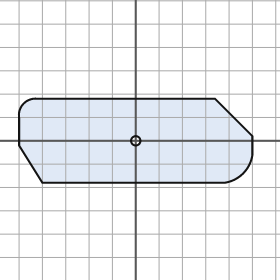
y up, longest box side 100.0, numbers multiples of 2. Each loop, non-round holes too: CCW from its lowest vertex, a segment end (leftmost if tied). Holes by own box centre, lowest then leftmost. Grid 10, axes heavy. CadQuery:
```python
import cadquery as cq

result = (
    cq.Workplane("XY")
    .moveTo(-40.0, -18.0)
    .lineTo(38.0, -18.0)
    .threePointArc((46.0, -14.0), (50.0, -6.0))
    .lineTo(50.0, 2.0)
    .lineTo(34.0, 18.0)
    .lineTo(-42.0, 18.0)
    .threePointArc((-48.0, 16.0), (-50.0, 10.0))
    .lineTo(-50.0, -2.0)
    .close()
    .moveTo(0.0, 0.0)
    .circle(2.0)
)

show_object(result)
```